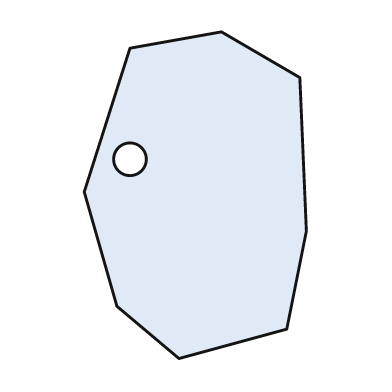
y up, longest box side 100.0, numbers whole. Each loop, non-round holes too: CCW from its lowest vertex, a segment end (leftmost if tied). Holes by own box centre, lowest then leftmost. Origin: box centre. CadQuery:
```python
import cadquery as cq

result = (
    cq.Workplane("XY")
    .moveTo(-5.0, -50.0)
    .lineTo(28.0, -41.0)
    .lineTo(34.0, -11.0)
    .lineTo(32.0, 36.0)
    .lineTo(8.0, 50.0)
    .lineTo(-20.0, 45.0)
    .lineTo(-34.0, 1.0)
    .lineTo(-24.0, -34.0)
    .close()
    .moveTo(-20.0, 11.0)
    .circle(5.0)
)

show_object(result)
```